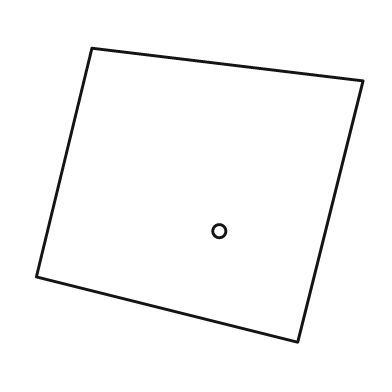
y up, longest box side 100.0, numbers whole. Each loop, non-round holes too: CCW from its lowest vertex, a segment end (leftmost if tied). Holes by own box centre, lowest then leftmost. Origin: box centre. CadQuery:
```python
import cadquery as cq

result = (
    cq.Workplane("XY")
    .moveTo(30.0, -45.0)
    .lineTo(50.0, 35.0)
    .lineTo(-33.0, 45.0)
    .lineTo(-50.0, -25.0)
    .close()
    .moveTo(6.0, -11.0)
    .circle(2.0)
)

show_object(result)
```